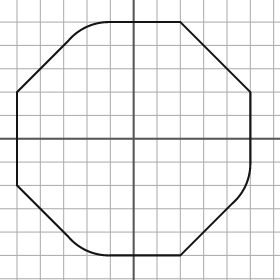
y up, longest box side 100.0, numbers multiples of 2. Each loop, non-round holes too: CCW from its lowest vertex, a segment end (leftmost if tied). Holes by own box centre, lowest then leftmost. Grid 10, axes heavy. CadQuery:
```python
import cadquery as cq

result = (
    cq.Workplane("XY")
    .moveTo(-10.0, -50.0)
    .lineTo(20.0, -50.0)
    .lineTo(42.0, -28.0)
    .threePointArc((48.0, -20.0), (50.0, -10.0))
    .lineTo(50.0, 20.0)
    .lineTo(20.0, 50.0)
    .lineTo(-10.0, 50.0)
    .threePointArc((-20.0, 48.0), (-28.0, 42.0))
    .lineTo(-50.0, 20.0)
    .lineTo(-50.0, -20.0)
    .lineTo(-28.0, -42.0)
    .threePointArc((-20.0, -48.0), (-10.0, -50.0))
    .close()
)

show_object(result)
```